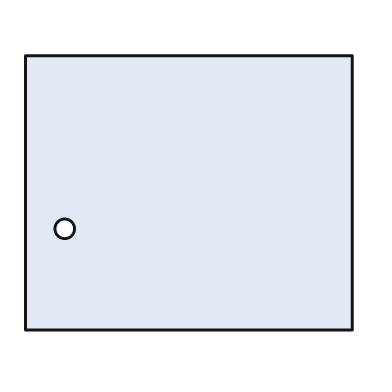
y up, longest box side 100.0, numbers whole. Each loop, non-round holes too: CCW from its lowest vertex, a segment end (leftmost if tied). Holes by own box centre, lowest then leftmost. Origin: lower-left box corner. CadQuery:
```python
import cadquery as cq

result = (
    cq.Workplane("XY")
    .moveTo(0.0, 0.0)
    .lineTo(100.0, 0.0)
    .lineTo(100.0, 84.0)
    .lineTo(0.0, 84.0)
    .close()
    .moveTo(12.0, 31.0)
    .circle(3.0)
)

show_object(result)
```